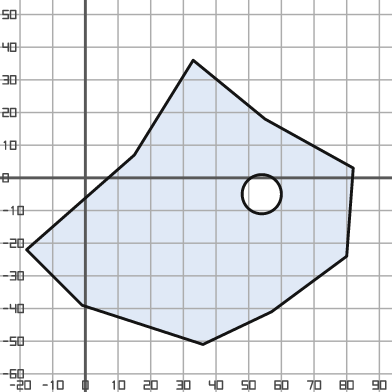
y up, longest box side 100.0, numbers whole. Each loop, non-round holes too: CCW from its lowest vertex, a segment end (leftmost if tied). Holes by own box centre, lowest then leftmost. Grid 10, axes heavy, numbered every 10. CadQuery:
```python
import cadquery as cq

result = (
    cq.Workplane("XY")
    .moveTo(36.0, -51.0)
    .lineTo(57.0, -41.0)
    .lineTo(80.0, -24.0)
    .lineTo(82.0, 3.0)
    .lineTo(55.0, 18.0)
    .lineTo(33.0, 36.0)
    .lineTo(15.0, 7.0)
    .lineTo(-18.0, -22.0)
    .lineTo(-1.0, -39.0)
    .close()
    .moveTo(54.0, -5.0)
    .circle(6.0)
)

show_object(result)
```